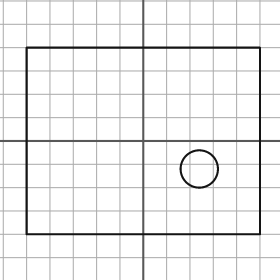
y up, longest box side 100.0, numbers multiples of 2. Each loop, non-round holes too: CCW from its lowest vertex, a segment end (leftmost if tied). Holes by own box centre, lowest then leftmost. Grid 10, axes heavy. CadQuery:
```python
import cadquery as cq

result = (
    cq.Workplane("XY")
    .moveTo(-50.0, -40.0)
    .lineTo(50.0, -40.0)
    .lineTo(50.0, 40.0)
    .lineTo(-50.0, 40.0)
    .close()
    .moveTo(24.0, -12.0)
    .circle(8.0)
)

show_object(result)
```